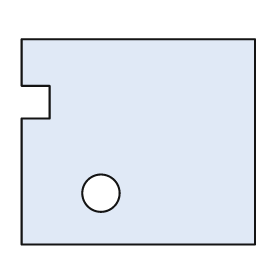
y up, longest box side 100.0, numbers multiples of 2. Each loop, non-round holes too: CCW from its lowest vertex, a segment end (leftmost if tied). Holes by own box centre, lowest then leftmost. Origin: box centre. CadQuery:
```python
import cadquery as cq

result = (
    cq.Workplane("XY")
    .moveTo(-50.0, -44.0)
    .lineTo(50.0, -44.0)
    .lineTo(50.0, 44.0)
    .lineTo(-50.0, 44.0)
    .lineTo(-50.0, 24.0)
    .lineTo(-38.0, 24.0)
    .lineTo(-38.0, 10.0)
    .lineTo(-50.0, 10.0)
    .close()
    .moveTo(-16.0, -22.0)
    .circle(8.0)
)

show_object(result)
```